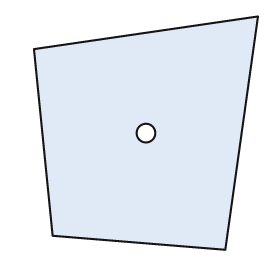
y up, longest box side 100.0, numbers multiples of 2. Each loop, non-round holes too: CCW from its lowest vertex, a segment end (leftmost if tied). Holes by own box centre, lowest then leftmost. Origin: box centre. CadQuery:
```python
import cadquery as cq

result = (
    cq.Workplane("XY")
    .moveTo(34.0, -50.0)
    .lineTo(48.0, 50.0)
    .lineTo(-48.0, 36.0)
    .lineTo(-40.0, -44.0)
    .close()
    .moveTo(0.0, 0.0)
    .circle(4.0)
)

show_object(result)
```